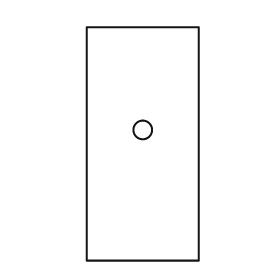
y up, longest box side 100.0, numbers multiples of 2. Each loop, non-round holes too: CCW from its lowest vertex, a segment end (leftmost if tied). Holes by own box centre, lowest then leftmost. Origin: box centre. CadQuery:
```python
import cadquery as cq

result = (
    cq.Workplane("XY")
    .moveTo(-24.0, -50.0)
    .lineTo(24.0, -50.0)
    .lineTo(24.0, 50.0)
    .lineTo(-24.0, 50.0)
    .close()
    .moveTo(0.0, 6.0)
    .circle(4.0)
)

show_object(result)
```